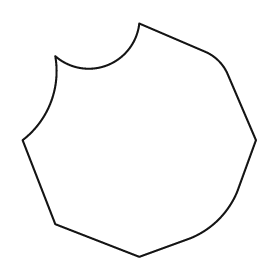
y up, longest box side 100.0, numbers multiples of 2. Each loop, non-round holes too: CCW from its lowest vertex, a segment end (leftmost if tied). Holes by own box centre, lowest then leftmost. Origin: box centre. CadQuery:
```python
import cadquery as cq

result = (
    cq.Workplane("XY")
    .moveTo(0.0, -50.0)
    .lineTo(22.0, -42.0)
    .threePointArc((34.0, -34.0), (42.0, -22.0))
    .lineTo(50.0, 0.0)
    .lineTo(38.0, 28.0)
    .threePointArc((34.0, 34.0), (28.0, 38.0))
    .lineTo(0.0, 50.0)
    .threePointArc((-14.0, 32.0), (-36.0, 36.0))
    .threePointArc((-38.0, 16.0), (-50.0, 0.0))
    .lineTo(-36.0, -36.0)
    .close()
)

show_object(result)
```